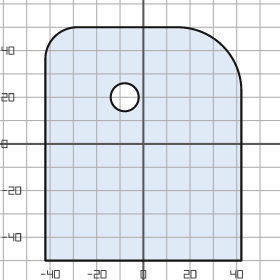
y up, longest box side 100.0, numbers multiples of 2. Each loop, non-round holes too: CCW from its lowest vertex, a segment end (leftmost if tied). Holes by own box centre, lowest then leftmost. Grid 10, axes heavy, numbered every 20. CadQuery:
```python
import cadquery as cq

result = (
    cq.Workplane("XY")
    .moveTo(-42.0, -50.0)
    .lineTo(42.0, -50.0)
    .lineTo(42.0, 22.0)
    .threePointArc((34.0, 42.0), (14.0, 50.0))
    .lineTo(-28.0, 50.0)
    .threePointArc((-38.0, 46.0), (-42.0, 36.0))
    .close()
    .moveTo(-8.0, 20.0)
    .circle(6.0)
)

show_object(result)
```